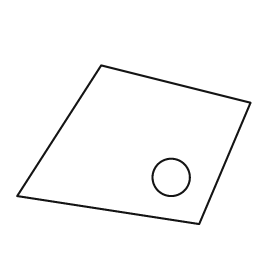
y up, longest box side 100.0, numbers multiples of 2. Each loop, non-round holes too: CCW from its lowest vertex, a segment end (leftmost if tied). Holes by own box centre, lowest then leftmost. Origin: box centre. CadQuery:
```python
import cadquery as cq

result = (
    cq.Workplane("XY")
    .moveTo(28.0, -34.0)
    .lineTo(50.0, 18.0)
    .lineTo(-14.0, 34.0)
    .lineTo(-50.0, -22.0)
    .close()
    .moveTo(16.0, -14.0)
    .circle(8.0)
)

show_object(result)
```